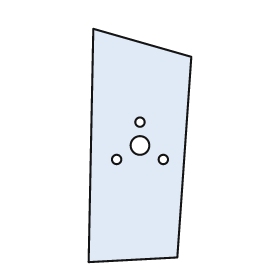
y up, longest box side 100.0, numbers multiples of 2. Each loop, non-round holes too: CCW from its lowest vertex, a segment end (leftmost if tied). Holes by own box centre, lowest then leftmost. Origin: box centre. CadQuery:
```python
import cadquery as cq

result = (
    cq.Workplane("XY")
    .moveTo(-22.0, -50.0)
    .lineTo(16.0, -48.0)
    .lineTo(22.0, 38.0)
    .lineTo(-20.0, 50.0)
    .close()
    .moveTo(-10.0, -6.0)
    .circle(2.0)
    .moveTo(10.0, -6.0)
    .circle(2.0)
    .moveTo(0.0, 0.0)
    .circle(4.0)
    .moveTo(0.0, 10.0)
    .circle(2.0)
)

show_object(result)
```